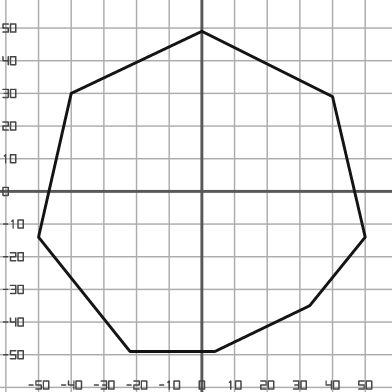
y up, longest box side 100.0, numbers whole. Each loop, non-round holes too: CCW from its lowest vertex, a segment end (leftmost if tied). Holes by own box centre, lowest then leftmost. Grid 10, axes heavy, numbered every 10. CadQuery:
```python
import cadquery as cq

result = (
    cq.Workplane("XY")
    .moveTo(-22.0, -49.0)
    .lineTo(4.0, -49.0)
    .lineTo(33.0, -35.0)
    .lineTo(50.0, -14.0)
    .lineTo(40.0, 29.0)
    .lineTo(0.0, 49.0)
    .lineTo(-40.0, 30.0)
    .lineTo(-50.0, -14.0)
    .close()
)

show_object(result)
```